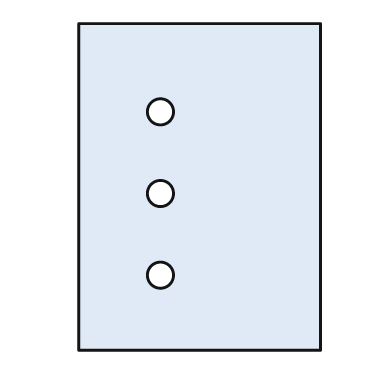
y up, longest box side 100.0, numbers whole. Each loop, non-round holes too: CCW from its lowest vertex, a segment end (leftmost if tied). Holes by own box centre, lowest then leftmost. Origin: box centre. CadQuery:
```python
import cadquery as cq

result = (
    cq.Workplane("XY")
    .moveTo(-37.0, -50.0)
    .lineTo(37.0, -50.0)
    .lineTo(37.0, 50.0)
    .lineTo(-37.0, 50.0)
    .close()
    .moveTo(-12.0, -27.0)
    .circle(4.0)
    .moveTo(-12.0, -2.0)
    .circle(4.0)
    .moveTo(-12.0, 23.0)
    .circle(4.0)
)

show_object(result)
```